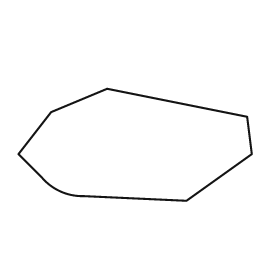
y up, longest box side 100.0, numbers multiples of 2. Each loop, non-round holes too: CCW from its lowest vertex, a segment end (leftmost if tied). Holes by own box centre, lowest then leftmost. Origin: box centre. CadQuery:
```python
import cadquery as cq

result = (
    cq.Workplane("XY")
    .moveTo(22.0, -24.0)
    .lineTo(50.0, -4.0)
    .lineTo(48.0, 12.0)
    .lineTo(-12.0, 24.0)
    .lineTo(-36.0, 14.0)
    .lineTo(-50.0, -4.0)
    .lineTo(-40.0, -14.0)
    .threePointArc((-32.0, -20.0), (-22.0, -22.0))
    .close()
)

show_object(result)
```